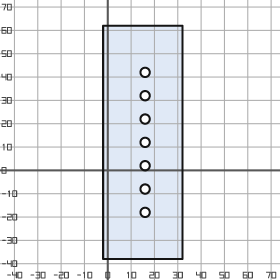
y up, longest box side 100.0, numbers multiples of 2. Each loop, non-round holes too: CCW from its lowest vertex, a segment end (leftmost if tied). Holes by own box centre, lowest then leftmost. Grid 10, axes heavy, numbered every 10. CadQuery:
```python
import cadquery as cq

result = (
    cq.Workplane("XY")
    .moveTo(-2.0, -38.0)
    .lineTo(32.0, -38.0)
    .lineTo(32.0, 62.0)
    .lineTo(-2.0, 62.0)
    .close()
    .moveTo(16.0, -18.0)
    .circle(2.0)
    .moveTo(16.0, -8.0)
    .circle(2.0)
    .moveTo(16.0, 2.0)
    .circle(2.0)
    .moveTo(16.0, 12.0)
    .circle(2.0)
    .moveTo(16.0, 22.0)
    .circle(2.0)
    .moveTo(16.0, 32.0)
    .circle(2.0)
    .moveTo(16.0, 42.0)
    .circle(2.0)
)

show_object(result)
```